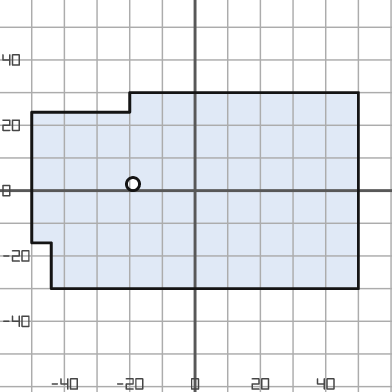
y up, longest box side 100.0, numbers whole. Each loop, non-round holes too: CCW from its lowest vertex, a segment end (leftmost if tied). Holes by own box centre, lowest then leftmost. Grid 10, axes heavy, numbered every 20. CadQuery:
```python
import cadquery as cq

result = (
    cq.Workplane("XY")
    .moveTo(-44.0, -30.0)
    .lineTo(50.0, -30.0)
    .lineTo(50.0, 30.0)
    .lineTo(-20.0, 30.0)
    .lineTo(-20.0, 24.0)
    .lineTo(-50.0, 24.0)
    .lineTo(-50.0, -16.0)
    .lineTo(-44.0, -16.0)
    .close()
    .moveTo(-19.0, 2.0)
    .circle(2.0)
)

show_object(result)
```